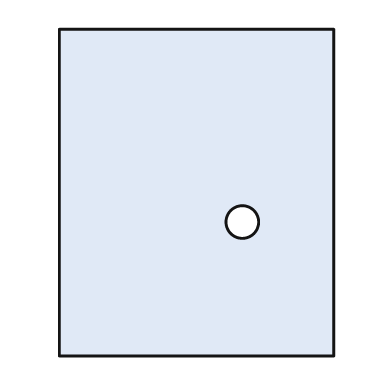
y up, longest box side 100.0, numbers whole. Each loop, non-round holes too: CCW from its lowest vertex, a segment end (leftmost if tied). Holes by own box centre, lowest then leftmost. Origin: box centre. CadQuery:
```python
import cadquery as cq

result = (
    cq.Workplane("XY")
    .moveTo(-42.0, -50.0)
    .lineTo(42.0, -50.0)
    .lineTo(42.0, 50.0)
    .lineTo(-42.0, 50.0)
    .close()
    .moveTo(14.0, -9.0)
    .circle(5.0)
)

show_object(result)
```